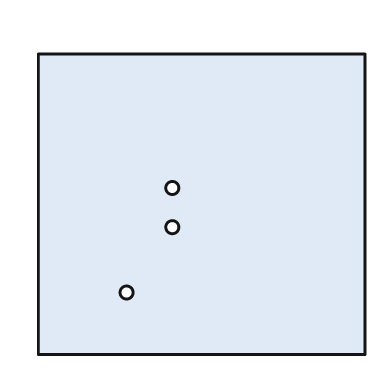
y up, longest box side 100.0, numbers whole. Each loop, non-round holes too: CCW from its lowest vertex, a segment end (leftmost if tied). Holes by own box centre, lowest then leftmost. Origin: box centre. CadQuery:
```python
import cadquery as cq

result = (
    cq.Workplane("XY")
    .moveTo(-50.0, -46.0)
    .lineTo(50.0, -46.0)
    .lineTo(50.0, 46.0)
    .lineTo(-50.0, 46.0)
    .close()
    .moveTo(-23.0, -27.0)
    .circle(2.0)
    .moveTo(-9.0, -7.0)
    .circle(2.0)
    .moveTo(-9.0, 5.0)
    .circle(2.0)
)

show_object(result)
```